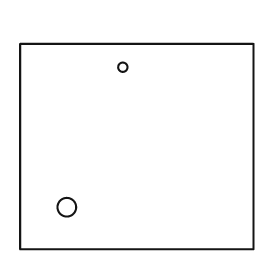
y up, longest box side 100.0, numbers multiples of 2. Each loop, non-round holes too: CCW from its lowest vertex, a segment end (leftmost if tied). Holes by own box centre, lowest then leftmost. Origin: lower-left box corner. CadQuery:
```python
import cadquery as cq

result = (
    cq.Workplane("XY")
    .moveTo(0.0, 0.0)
    .lineTo(100.0, 0.0)
    .lineTo(100.0, 88.0)
    .lineTo(0.0, 88.0)
    .close()
    .moveTo(20.0, 18.0)
    .circle(4.0)
    .moveTo(44.0, 78.0)
    .circle(2.0)
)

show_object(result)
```